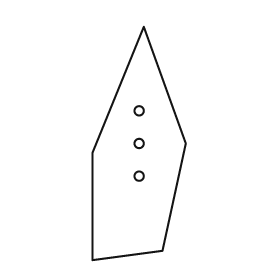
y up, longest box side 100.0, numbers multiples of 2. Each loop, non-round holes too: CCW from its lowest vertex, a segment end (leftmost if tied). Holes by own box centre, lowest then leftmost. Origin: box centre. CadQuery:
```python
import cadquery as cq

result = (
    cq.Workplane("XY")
    .moveTo(-20.0, -50.0)
    .lineTo(10.0, -46.0)
    .lineTo(20.0, 0.0)
    .lineTo(2.0, 50.0)
    .lineTo(-20.0, -4.0)
    .close()
    .moveTo(0.0, -14.0)
    .circle(2.0)
    .moveTo(0.0, 0.0)
    .circle(2.0)
    .moveTo(0.0, 14.0)
    .circle(2.0)
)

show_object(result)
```